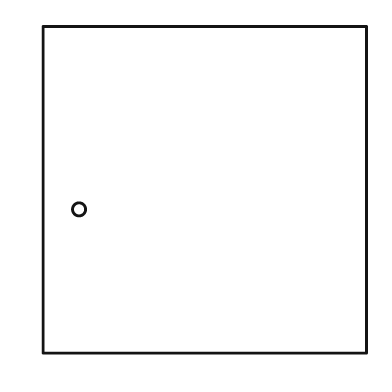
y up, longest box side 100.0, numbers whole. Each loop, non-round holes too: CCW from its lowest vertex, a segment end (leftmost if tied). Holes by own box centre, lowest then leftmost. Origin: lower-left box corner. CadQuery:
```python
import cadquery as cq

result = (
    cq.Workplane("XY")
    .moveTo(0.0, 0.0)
    .lineTo(99.0, 0.0)
    .lineTo(99.0, 100.0)
    .lineTo(0.0, 100.0)
    .close()
    .moveTo(11.0, 44.0)
    .circle(2.0)
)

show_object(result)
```